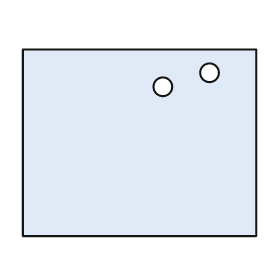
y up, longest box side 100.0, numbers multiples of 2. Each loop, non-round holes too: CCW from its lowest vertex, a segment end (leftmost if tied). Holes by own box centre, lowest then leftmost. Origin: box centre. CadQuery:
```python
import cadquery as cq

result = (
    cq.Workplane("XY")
    .moveTo(-50.0, -40.0)
    .lineTo(50.0, -40.0)
    .lineTo(50.0, 40.0)
    .lineTo(-50.0, 40.0)
    .close()
    .moveTo(10.0, 24.0)
    .circle(4.0)
    .moveTo(30.0, 30.0)
    .circle(4.0)
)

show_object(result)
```